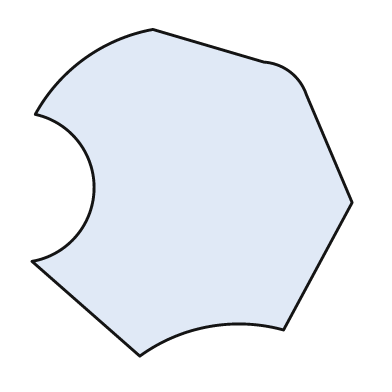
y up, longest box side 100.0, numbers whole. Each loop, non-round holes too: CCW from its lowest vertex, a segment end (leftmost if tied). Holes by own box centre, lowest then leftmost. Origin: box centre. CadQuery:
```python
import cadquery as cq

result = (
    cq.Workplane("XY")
    .moveTo(-16.0, -50.0)
    .threePointArc((5.0, -41.0), (28.0, -42.0))
    .lineTo(49.0, -3.0)
    .lineTo(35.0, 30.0)
    .threePointArc((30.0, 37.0), (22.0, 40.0))
    .lineTo(-12.0, 50.0)
    .threePointArc((-33.0, 41.0), (-48.0, 24.0))
    .threePointArc((-30.0, 1.0), (-49.0, -21.0))
    .close()
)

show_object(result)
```